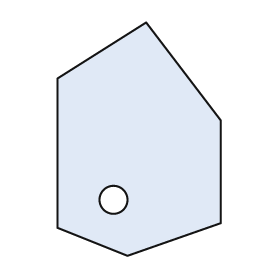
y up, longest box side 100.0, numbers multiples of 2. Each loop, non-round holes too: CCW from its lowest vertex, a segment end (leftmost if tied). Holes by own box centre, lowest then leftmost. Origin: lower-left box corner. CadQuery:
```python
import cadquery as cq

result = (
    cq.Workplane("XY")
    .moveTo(30.0, 0.0)
    .lineTo(70.0, 14.0)
    .lineTo(70.0, 58.0)
    .lineTo(38.0, 100.0)
    .lineTo(0.0, 76.0)
    .lineTo(0.0, 12.0)
    .close()
    .moveTo(24.0, 24.0)
    .circle(6.0)
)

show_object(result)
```